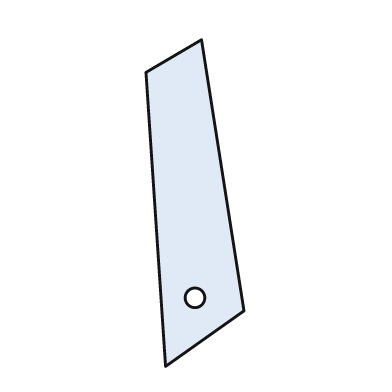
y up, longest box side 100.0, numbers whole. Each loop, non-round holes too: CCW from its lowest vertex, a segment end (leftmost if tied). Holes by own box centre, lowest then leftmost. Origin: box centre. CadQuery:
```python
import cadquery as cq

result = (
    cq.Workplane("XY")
    .moveTo(-9.0, -50.0)
    .lineTo(15.0, -33.0)
    .lineTo(2.0, 50.0)
    .lineTo(-15.0, 40.0)
    .close()
    .moveTo(0.0, -29.0)
    .circle(3.0)
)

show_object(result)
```